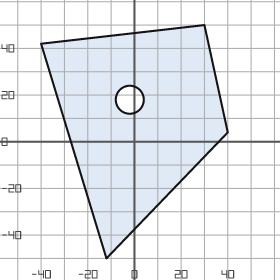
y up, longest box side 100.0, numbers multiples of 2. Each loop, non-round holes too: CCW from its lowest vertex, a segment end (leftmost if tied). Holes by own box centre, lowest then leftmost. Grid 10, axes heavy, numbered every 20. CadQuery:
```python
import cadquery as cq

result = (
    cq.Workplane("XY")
    .moveTo(-12.0, -50.0)
    .lineTo(40.0, 4.0)
    .lineTo(30.0, 50.0)
    .lineTo(-40.0, 42.0)
    .close()
    .moveTo(-2.0, 18.0)
    .circle(6.0)
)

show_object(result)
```